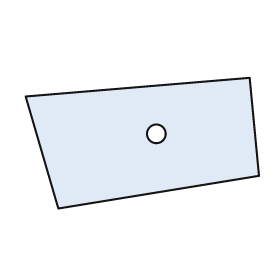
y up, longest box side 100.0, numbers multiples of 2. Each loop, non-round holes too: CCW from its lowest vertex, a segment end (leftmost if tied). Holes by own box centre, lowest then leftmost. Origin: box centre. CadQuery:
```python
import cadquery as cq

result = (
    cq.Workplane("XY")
    .moveTo(-36.0, -28.0)
    .lineTo(50.0, -14.0)
    .lineTo(46.0, 28.0)
    .lineTo(-50.0, 20.0)
    .close()
    .moveTo(6.0, 4.0)
    .circle(4.0)
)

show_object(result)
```